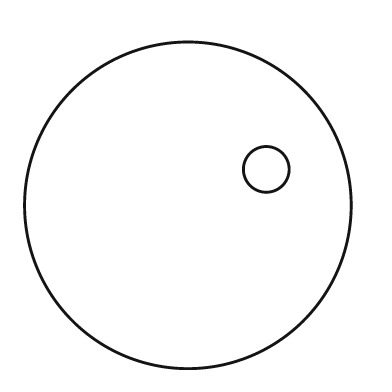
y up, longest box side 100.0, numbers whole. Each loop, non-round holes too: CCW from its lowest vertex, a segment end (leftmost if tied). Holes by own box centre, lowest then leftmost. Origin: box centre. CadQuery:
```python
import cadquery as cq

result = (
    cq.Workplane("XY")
    .moveTo(0.0, 0.0)
    .circle(50.0)
    .moveTo(24.0, 11.0)
    .circle(7.0)
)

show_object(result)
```